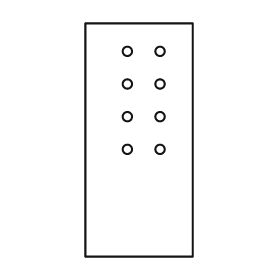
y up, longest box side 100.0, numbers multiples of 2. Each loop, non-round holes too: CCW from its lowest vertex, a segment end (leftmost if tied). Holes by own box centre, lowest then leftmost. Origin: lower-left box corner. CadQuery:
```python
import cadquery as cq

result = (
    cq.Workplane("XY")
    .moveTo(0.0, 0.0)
    .lineTo(46.0, 0.0)
    .lineTo(46.0, 100.0)
    .lineTo(0.0, 100.0)
    .close()
    .moveTo(18.0, 46.0)
    .circle(2.0)
    .moveTo(32.0, 46.0)
    .circle(2.0)
    .moveTo(18.0, 60.0)
    .circle(2.0)
    .moveTo(32.0, 60.0)
    .circle(2.0)
    .moveTo(18.0, 74.0)
    .circle(2.0)
    .moveTo(32.0, 74.0)
    .circle(2.0)
    .moveTo(18.0, 88.0)
    .circle(2.0)
    .moveTo(32.0, 88.0)
    .circle(2.0)
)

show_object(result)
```